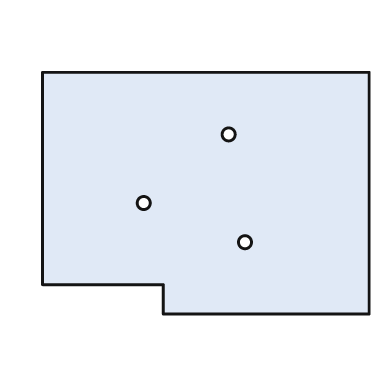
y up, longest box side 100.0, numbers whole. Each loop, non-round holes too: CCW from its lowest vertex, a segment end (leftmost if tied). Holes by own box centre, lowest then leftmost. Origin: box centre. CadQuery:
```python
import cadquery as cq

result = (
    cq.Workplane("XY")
    .moveTo(-13.0, -37.0)
    .lineTo(50.0, -37.0)
    .lineTo(50.0, 37.0)
    .lineTo(-50.0, 37.0)
    .lineTo(-50.0, -28.0)
    .lineTo(-13.0, -28.0)
    .close()
    .moveTo(12.0, -15.0)
    .circle(2.0)
    .moveTo(-19.0, -3.0)
    .circle(2.0)
    .moveTo(7.0, 18.0)
    .circle(2.0)
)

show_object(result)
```